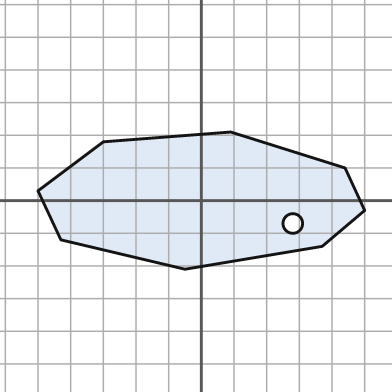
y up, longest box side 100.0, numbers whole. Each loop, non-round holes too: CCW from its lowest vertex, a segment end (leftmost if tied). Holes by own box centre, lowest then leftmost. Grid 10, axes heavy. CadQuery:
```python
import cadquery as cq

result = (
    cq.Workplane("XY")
    .moveTo(-5.0, -21.0)
    .lineTo(37.0, -14.0)
    .lineTo(50.0, -3.0)
    .lineTo(44.0, 10.0)
    .lineTo(9.0, 21.0)
    .lineTo(-30.0, 18.0)
    .lineTo(-50.0, 3.0)
    .lineTo(-43.0, -12.0)
    .close()
    .moveTo(28.0, -7.0)
    .circle(3.0)
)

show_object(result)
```